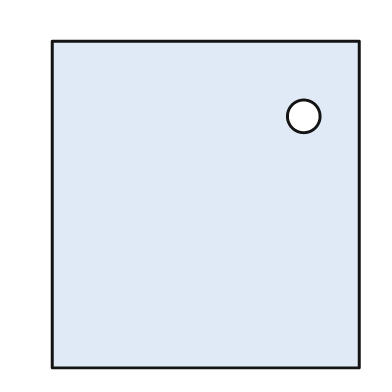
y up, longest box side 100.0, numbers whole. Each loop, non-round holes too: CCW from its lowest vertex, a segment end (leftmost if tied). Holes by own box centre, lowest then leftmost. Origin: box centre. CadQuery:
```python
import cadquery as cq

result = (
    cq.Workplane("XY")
    .moveTo(-47.0, -50.0)
    .lineTo(47.0, -50.0)
    .lineTo(47.0, 50.0)
    .lineTo(-47.0, 50.0)
    .close()
    .moveTo(30.0, 27.0)
    .circle(5.0)
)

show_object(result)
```